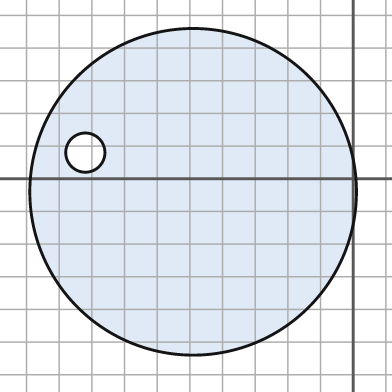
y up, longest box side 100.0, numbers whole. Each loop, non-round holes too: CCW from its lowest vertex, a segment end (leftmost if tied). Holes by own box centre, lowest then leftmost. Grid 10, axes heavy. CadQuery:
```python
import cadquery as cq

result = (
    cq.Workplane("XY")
    .moveTo(-49.0, -4.0)
    .circle(50.0)
    .moveTo(-82.0, 8.0)
    .circle(6.0)
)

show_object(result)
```